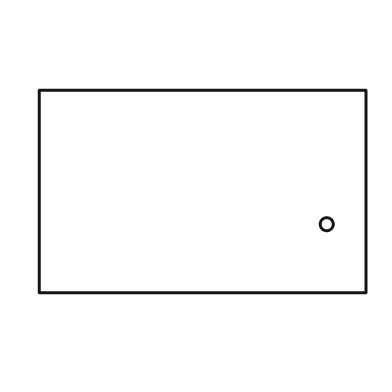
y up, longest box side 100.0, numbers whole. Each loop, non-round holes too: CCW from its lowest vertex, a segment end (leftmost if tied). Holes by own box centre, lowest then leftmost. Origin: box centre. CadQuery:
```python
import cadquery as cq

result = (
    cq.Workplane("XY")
    .moveTo(-50.0, -31.0)
    .lineTo(50.0, -31.0)
    .lineTo(50.0, 31.0)
    .lineTo(-50.0, 31.0)
    .close()
    .moveTo(38.0, -10.0)
    .circle(2.0)
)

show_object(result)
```